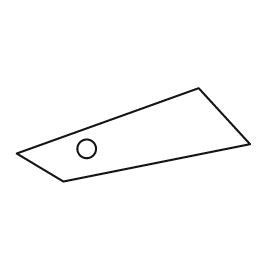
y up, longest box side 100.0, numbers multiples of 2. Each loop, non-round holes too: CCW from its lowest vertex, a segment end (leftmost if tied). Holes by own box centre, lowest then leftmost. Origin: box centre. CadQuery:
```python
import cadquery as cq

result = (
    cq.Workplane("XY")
    .moveTo(-30.0, -20.0)
    .lineTo(50.0, -4.0)
    .lineTo(28.0, 20.0)
    .lineTo(-50.0, -8.0)
    .close()
    .moveTo(-20.0, -6.0)
    .circle(4.0)
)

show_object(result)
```